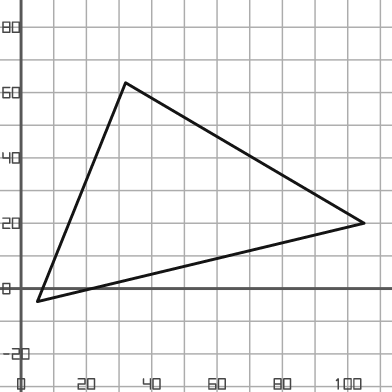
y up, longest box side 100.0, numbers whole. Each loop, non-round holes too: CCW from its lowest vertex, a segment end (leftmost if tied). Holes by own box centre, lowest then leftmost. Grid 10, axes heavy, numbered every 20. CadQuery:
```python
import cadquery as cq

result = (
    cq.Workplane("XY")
    .moveTo(5.0, -4.0)
    .lineTo(105.0, 20.0)
    .lineTo(32.0, 63.0)
    .close()
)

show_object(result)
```